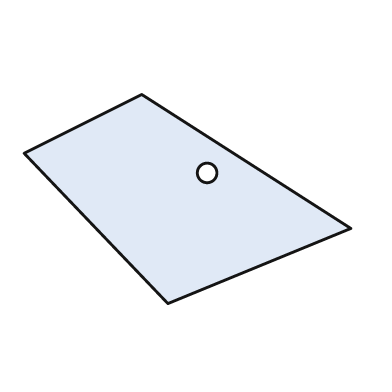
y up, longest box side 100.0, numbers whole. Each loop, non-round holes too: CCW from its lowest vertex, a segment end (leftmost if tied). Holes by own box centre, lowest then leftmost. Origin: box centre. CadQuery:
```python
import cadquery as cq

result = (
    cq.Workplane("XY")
    .moveTo(-6.0, -32.0)
    .lineTo(50.0, -9.0)
    .lineTo(-14.0, 32.0)
    .lineTo(-50.0, 14.0)
    .close()
    .moveTo(6.0, 8.0)
    .circle(3.0)
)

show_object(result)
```